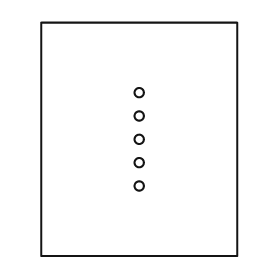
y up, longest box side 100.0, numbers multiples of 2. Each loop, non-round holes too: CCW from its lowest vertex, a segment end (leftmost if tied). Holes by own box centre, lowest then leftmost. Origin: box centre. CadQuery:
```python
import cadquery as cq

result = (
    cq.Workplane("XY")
    .moveTo(-42.0, -50.0)
    .lineTo(42.0, -50.0)
    .lineTo(42.0, 50.0)
    .lineTo(-42.0, 50.0)
    .close()
    .moveTo(0.0, -20.0)
    .circle(2.0)
    .moveTo(0.0, -10.0)
    .circle(2.0)
    .moveTo(0.0, 0.0)
    .circle(2.0)
    .moveTo(0.0, 10.0)
    .circle(2.0)
    .moveTo(0.0, 20.0)
    .circle(2.0)
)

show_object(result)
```